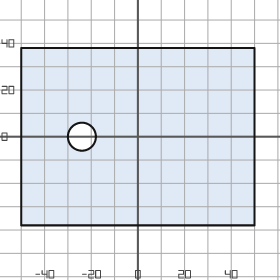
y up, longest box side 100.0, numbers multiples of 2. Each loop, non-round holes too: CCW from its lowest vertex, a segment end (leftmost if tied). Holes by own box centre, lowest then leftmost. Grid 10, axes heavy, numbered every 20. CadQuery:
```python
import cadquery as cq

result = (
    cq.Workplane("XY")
    .moveTo(-50.0, -38.0)
    .lineTo(50.0, -38.0)
    .lineTo(50.0, 38.0)
    .lineTo(-50.0, 38.0)
    .close()
    .moveTo(-24.0, 0.0)
    .circle(6.0)
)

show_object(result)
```